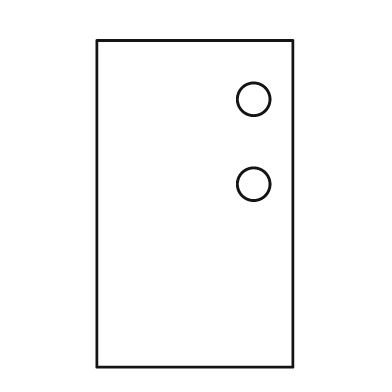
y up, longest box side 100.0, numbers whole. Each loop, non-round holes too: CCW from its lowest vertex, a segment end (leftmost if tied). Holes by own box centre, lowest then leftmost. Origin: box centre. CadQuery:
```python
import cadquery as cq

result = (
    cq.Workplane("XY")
    .moveTo(-30.0, -50.0)
    .lineTo(30.0, -50.0)
    .lineTo(30.0, 50.0)
    .lineTo(-30.0, 50.0)
    .close()
    .moveTo(18.0, 6.0)
    .circle(5.0)
    .moveTo(18.0, 32.0)
    .circle(5.0)
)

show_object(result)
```